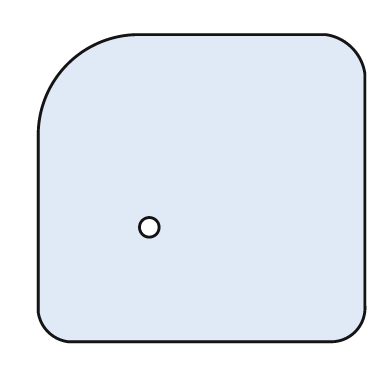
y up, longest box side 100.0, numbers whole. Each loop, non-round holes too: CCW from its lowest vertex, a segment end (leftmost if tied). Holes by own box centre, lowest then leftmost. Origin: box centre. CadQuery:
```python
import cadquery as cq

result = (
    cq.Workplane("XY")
    .moveTo(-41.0, -47.0)
    .lineTo(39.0, -47.0)
    .threePointArc((47.0, -44.0), (50.0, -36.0))
    .lineTo(50.0, 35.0)
    .threePointArc((46.0, 43.0), (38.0, 47.0))
    .lineTo(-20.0, 47.0)
    .threePointArc((-41.0, 38.0), (-50.0, 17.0))
    .lineTo(-50.0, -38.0)
    .threePointArc((-47.0, -44.0), (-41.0, -47.0))
    .close()
    .moveTo(-16.0, -12.0)
    .circle(3.0)
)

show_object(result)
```